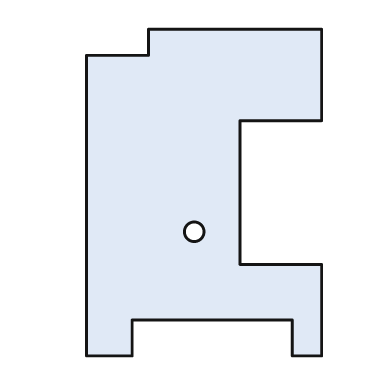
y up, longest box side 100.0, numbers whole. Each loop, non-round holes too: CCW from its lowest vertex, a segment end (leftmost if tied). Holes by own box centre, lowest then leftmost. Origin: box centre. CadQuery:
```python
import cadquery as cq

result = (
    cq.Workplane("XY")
    .moveTo(-36.0, -50.0)
    .lineTo(-22.0, -50.0)
    .lineTo(-22.0, -39.0)
    .lineTo(27.0, -39.0)
    .lineTo(27.0, -50.0)
    .lineTo(36.0, -50.0)
    .lineTo(36.0, -22.0)
    .lineTo(11.0, -22.0)
    .lineTo(11.0, 22.0)
    .lineTo(36.0, 22.0)
    .lineTo(36.0, 50.0)
    .lineTo(-17.0, 50.0)
    .lineTo(-17.0, 42.0)
    .lineTo(-36.0, 42.0)
    .close()
    .moveTo(-3.0, -12.0)
    .circle(3.0)
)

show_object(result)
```